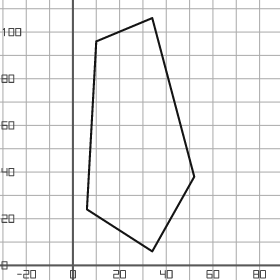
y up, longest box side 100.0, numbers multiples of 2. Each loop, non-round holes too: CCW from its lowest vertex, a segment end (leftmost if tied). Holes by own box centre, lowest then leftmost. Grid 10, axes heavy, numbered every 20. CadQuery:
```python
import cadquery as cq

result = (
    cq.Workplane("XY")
    .moveTo(34.0, 6.0)
    .lineTo(52.0, 38.0)
    .lineTo(34.0, 106.0)
    .lineTo(10.0, 96.0)
    .lineTo(6.0, 24.0)
    .close()
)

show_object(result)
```